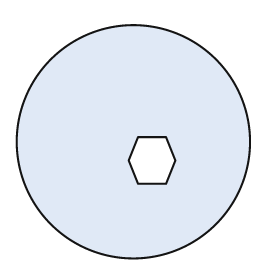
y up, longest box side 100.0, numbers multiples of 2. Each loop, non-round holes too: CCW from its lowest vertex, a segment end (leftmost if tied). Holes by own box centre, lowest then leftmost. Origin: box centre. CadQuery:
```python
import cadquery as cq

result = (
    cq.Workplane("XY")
    .moveTo(0.0, 0.0)
    .circle(50.0)
    .moveTo(2.0, -18.0)
    .lineTo(14.0, -18.0)
    .lineTo(18.0, -8.0)
    .lineTo(14.0, 2.0)
    .lineTo(2.0, 2.0)
    .lineTo(-2.0, -8.0)
    .close()
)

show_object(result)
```